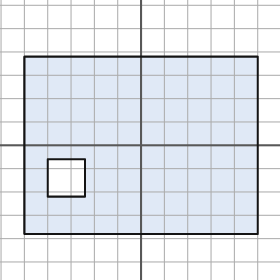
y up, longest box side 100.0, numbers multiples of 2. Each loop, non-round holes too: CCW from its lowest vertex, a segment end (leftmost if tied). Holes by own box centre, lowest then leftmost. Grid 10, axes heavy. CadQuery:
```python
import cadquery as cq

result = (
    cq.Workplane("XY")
    .moveTo(-50.0, -38.0)
    .lineTo(50.0, -38.0)
    .lineTo(50.0, 38.0)
    .lineTo(-50.0, 38.0)
    .close()
    .moveTo(-40.0, -22.0)
    .lineTo(-24.0, -22.0)
    .lineTo(-24.0, -6.0)
    .lineTo(-40.0, -6.0)
    .close()
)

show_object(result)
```